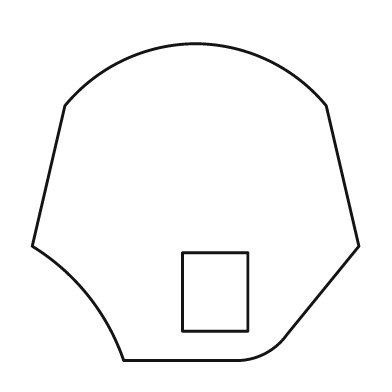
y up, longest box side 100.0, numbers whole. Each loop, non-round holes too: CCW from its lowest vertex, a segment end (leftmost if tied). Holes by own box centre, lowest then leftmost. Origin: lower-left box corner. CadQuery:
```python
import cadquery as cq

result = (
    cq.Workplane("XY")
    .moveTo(28.0, 0.0)
    .lineTo(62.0, 0.0)
    .threePointArc((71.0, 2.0), (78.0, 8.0))
    .lineTo(100.0, 35.0)
    .lineTo(90.0, 78.0)
    .threePointArc((72.0, 92.0), (50.0, 97.0))
    .threePointArc((28.0, 92.0), (10.0, 78.0))
    .lineTo(0.0, 35.0)
    .threePointArc((17.0, 20.0), (28.0, 0.0))
    .close()
    .moveTo(46.0, 9.0)
    .lineTo(66.0, 9.0)
    .lineTo(66.0, 33.0)
    .lineTo(46.0, 33.0)
    .close()
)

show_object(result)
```